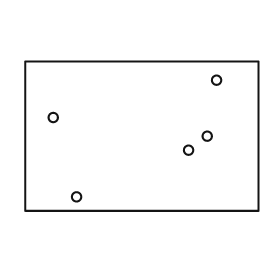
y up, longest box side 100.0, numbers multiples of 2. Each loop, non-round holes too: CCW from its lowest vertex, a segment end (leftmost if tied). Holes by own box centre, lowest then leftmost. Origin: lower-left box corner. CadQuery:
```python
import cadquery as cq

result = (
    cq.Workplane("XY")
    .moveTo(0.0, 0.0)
    .lineTo(100.0, 0.0)
    .lineTo(100.0, 64.0)
    .lineTo(0.0, 64.0)
    .close()
    .moveTo(22.0, 6.0)
    .circle(2.0)
    .moveTo(70.0, 26.0)
    .circle(2.0)
    .moveTo(78.0, 32.0)
    .circle(2.0)
    .moveTo(12.0, 40.0)
    .circle(2.0)
    .moveTo(82.0, 56.0)
    .circle(2.0)
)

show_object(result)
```